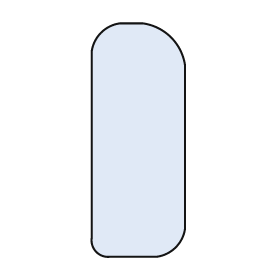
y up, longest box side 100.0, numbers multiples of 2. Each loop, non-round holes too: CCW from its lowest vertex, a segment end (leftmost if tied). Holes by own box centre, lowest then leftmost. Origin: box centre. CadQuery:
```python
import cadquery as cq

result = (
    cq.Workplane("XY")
    .moveTo(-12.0, -50.0)
    .lineTo(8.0, -50.0)
    .threePointArc((16.0, -46.0), (20.0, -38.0))
    .lineTo(20.0, 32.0)
    .threePointArc((14.0, 44.0), (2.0, 50.0))
    .lineTo(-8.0, 50.0)
    .threePointArc((-16.0, 46.0), (-20.0, 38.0))
    .lineTo(-20.0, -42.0)
    .threePointArc((-18.0, -48.0), (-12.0, -50.0))
    .close()
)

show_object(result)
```